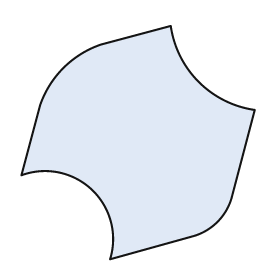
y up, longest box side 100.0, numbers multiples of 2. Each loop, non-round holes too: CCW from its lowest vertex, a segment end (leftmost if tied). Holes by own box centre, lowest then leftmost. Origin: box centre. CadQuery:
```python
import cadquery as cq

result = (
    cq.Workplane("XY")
    .moveTo(-12.0, -50.0)
    .lineTo(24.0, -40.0)
    .threePointArc((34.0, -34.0), (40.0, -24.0))
    .lineTo(50.0, 14.0)
    .threePointArc((26.0, 26.0), (14.0, 50.0))
    .lineTo(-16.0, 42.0)
    .threePointArc((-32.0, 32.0), (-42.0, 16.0))
    .lineTo(-50.0, -14.0)
    .threePointArc((-20.0, -20.0), (-12.0, -50.0))
    .close()
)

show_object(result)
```